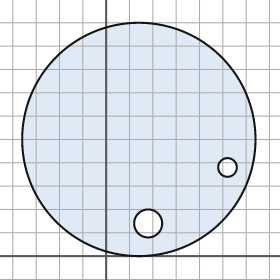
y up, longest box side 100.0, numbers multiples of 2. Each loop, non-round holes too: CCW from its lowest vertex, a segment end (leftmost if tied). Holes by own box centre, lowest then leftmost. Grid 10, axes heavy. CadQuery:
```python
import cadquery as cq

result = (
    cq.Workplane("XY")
    .moveTo(14.0, 50.0)
    .circle(50.0)
    .moveTo(18.0, 14.0)
    .circle(6.0)
    .moveTo(52.0, 38.0)
    .circle(4.0)
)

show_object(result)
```